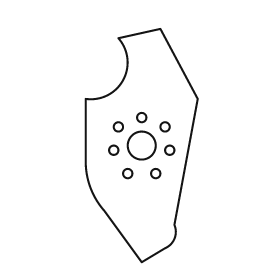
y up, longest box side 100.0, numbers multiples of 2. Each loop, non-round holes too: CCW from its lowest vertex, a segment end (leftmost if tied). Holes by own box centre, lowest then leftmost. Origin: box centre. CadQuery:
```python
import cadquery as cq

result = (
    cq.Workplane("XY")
    .moveTo(0.0, -50.0)
    .lineTo(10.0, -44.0)
    .threePointArc((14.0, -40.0), (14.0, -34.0))
    .lineTo(24.0, 20.0)
    .lineTo(8.0, 50.0)
    .lineTo(-10.0, 46.0)
    .threePointArc((-8.0, 28.0), (-24.0, 20.0))
    .lineTo(-24.0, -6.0)
    .threePointArc((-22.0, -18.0), (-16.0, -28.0))
    .close()
    .moveTo(-6.0, -12.0)
    .circle(2.0)
    .moveTo(6.0, -12.0)
    .circle(2.0)
    .moveTo(-12.0, -2.0)
    .circle(2.0)
    .moveTo(12.0, -2.0)
    .circle(2.0)
    .moveTo(0.0, 0.0)
    .circle(6.0)
    .moveTo(-10.0, 8.0)
    .circle(2.0)
    .moveTo(10.0, 8.0)
    .circle(2.0)
    .moveTo(0.0, 12.0)
    .circle(2.0)
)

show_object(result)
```